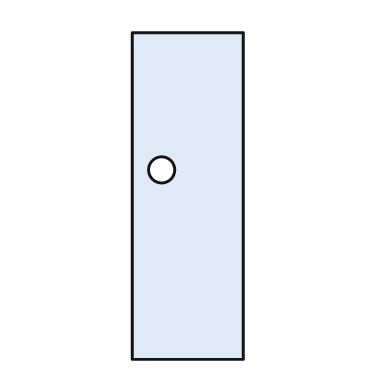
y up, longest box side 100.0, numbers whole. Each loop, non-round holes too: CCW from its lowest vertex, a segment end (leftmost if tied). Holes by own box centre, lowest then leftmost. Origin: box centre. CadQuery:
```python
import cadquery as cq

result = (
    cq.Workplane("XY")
    .moveTo(-17.0, -50.0)
    .lineTo(17.0, -50.0)
    .lineTo(17.0, 50.0)
    .lineTo(-17.0, 50.0)
    .close()
    .moveTo(-8.0, 8.0)
    .circle(4.0)
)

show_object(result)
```